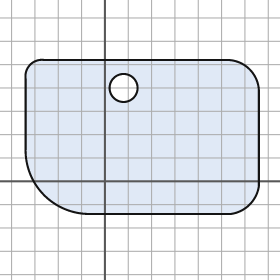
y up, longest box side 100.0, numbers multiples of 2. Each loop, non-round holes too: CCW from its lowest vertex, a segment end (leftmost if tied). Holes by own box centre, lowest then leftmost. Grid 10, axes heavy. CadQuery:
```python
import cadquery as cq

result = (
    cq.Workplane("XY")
    .moveTo(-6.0, -14.0)
    .lineTo(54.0, -14.0)
    .threePointArc((62.0, -10.0), (66.0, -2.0))
    .lineTo(66.0, 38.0)
    .threePointArc((62.0, 48.0), (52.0, 52.0))
    .lineTo(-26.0, 52.0)
    .threePointArc((-32.0, 50.0), (-34.0, 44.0))
    .lineTo(-34.0, 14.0)
    .threePointArc((-26.0, -6.0), (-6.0, -14.0))
    .close()
    .moveTo(8.0, 40.0)
    .circle(6.0)
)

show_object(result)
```